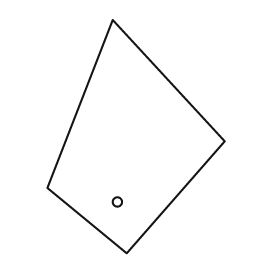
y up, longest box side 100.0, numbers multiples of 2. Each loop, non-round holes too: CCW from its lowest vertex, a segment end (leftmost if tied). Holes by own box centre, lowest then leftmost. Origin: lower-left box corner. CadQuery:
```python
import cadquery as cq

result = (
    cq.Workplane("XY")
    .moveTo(34.0, 0.0)
    .lineTo(76.0, 48.0)
    .lineTo(28.0, 100.0)
    .lineTo(0.0, 28.0)
    .close()
    .moveTo(30.0, 22.0)
    .circle(2.0)
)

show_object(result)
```